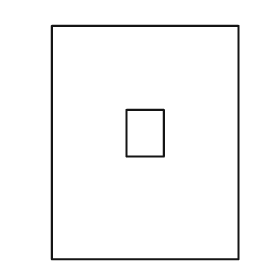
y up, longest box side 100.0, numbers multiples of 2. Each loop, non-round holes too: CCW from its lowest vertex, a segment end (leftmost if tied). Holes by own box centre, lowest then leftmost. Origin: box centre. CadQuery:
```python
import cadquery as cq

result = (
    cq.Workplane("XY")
    .moveTo(-40.0, -50.0)
    .lineTo(40.0, -50.0)
    .lineTo(40.0, 50.0)
    .lineTo(-40.0, 50.0)
    .close()
    .moveTo(-8.0, -6.0)
    .lineTo(8.0, -6.0)
    .lineTo(8.0, 14.0)
    .lineTo(-8.0, 14.0)
    .close()
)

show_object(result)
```